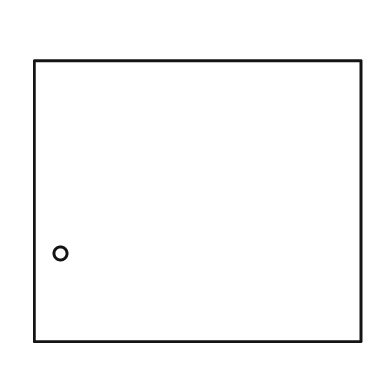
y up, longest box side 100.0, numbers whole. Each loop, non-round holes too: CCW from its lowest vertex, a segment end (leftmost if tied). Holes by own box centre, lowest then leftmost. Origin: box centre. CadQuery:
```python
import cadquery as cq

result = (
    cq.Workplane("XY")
    .moveTo(-50.0, -43.0)
    .lineTo(50.0, -43.0)
    .lineTo(50.0, 43.0)
    .lineTo(-50.0, 43.0)
    .close()
    .moveTo(-42.0, -16.0)
    .circle(2.0)
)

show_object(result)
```